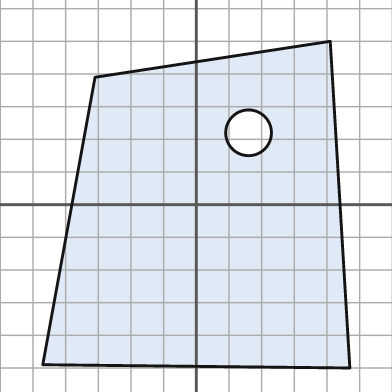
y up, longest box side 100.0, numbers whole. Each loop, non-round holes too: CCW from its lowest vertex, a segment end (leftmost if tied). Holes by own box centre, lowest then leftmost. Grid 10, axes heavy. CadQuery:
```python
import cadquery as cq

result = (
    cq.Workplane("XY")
    .moveTo(47.0, -50.0)
    .lineTo(41.0, 50.0)
    .lineTo(-31.0, 39.0)
    .lineTo(-47.0, -49.0)
    .close()
    .moveTo(16.0, 22.0)
    .circle(7.0)
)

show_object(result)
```